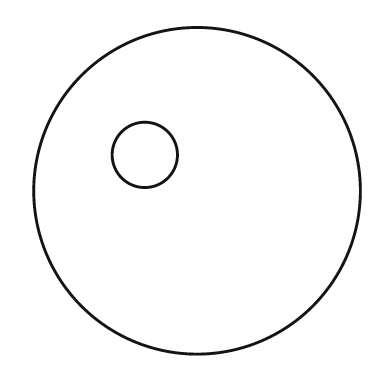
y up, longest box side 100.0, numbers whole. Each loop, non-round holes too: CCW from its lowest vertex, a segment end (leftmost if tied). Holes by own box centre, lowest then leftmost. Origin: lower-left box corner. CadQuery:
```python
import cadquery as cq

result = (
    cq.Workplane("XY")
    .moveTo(50.0, 50.0)
    .circle(50.0)
    .moveTo(34.0, 61.0)
    .circle(10.0)
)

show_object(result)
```